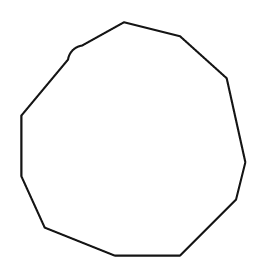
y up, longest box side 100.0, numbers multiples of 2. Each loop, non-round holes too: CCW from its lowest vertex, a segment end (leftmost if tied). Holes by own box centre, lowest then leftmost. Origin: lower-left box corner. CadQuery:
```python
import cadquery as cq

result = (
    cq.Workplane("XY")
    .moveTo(40.0, 0.0)
    .lineTo(68.0, 0.0)
    .lineTo(92.0, 24.0)
    .lineTo(96.0, 40.0)
    .lineTo(88.0, 76.0)
    .lineTo(68.0, 94.0)
    .lineTo(44.0, 100.0)
    .lineTo(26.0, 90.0)
    .threePointArc((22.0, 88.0), (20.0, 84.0))
    .lineTo(0.0, 60.0)
    .lineTo(0.0, 34.0)
    .lineTo(10.0, 12.0)
    .close()
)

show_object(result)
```